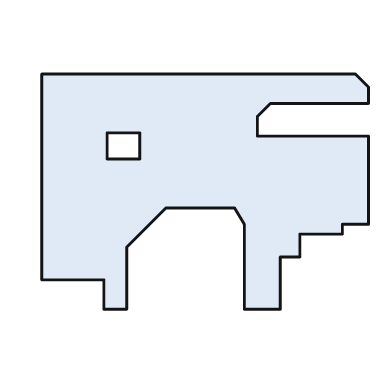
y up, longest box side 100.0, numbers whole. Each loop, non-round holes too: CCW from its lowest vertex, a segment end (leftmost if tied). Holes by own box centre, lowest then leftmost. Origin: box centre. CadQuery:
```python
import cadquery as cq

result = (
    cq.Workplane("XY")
    .moveTo(-31.0, -36.0)
    .lineTo(-24.0, -36.0)
    .lineTo(-24.0, -17.0)
    .lineTo(-12.0, -5.0)
    .lineTo(9.0, -5.0)
    .lineTo(12.0, -10.0)
    .lineTo(12.0, -36.0)
    .lineTo(23.0, -36.0)
    .lineTo(23.0, -20.0)
    .lineTo(29.0, -20.0)
    .lineTo(29.0, -13.0)
    .lineTo(42.0, -13.0)
    .lineTo(42.0, -10.0)
    .lineTo(50.0, -10.0)
    .lineTo(50.0, 17.0)
    .lineTo(16.0, 17.0)
    .lineTo(16.0, 23.0)
    .lineTo(20.0, 27.0)
    .lineTo(50.0, 27.0)
    .lineTo(50.0, 32.0)
    .lineTo(46.0, 36.0)
    .lineTo(-50.0, 36.0)
    .lineTo(-50.0, -27.0)
    .lineTo(-31.0, -27.0)
    .close()
    .moveTo(-30.0, 10.0)
    .lineTo(-20.0, 10.0)
    .lineTo(-20.0, 18.0)
    .lineTo(-30.0, 18.0)
    .close()
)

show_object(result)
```